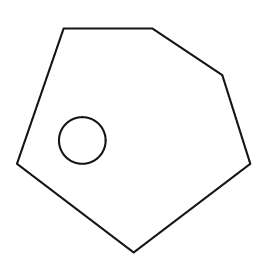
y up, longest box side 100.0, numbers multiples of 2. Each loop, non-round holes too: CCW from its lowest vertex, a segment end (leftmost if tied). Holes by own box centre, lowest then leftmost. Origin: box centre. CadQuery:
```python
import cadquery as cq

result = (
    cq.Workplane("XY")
    .moveTo(0.0, -48.0)
    .lineTo(50.0, -10.0)
    .lineTo(38.0, 28.0)
    .lineTo(8.0, 48.0)
    .lineTo(-30.0, 48.0)
    .lineTo(-50.0, -10.0)
    .close()
    .moveTo(-22.0, 0.0)
    .circle(10.0)
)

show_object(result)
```